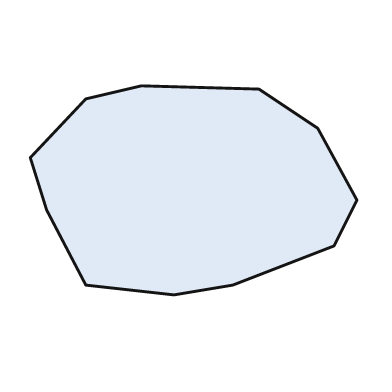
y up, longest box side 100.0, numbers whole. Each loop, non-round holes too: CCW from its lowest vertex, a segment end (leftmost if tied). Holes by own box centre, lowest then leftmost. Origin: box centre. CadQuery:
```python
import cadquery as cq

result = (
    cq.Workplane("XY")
    .moveTo(-6.0, -32.0)
    .lineTo(12.0, -29.0)
    .lineTo(43.0, -17.0)
    .lineTo(50.0, -3.0)
    .lineTo(38.0, 19.0)
    .lineTo(20.0, 31.0)
    .lineTo(-16.0, 32.0)
    .lineTo(-33.0, 28.0)
    .lineTo(-50.0, 10.0)
    .lineTo(-45.0, -6.0)
    .lineTo(-33.0, -29.0)
    .close()
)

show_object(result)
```